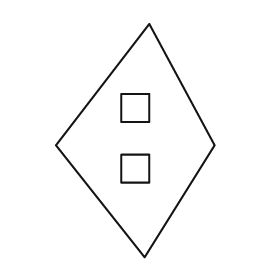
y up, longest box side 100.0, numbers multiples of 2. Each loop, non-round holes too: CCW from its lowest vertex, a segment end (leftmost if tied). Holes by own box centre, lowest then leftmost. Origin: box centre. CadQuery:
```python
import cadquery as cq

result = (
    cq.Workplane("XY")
    .moveTo(4.0, -50.0)
    .lineTo(34.0, -2.0)
    .lineTo(6.0, 50.0)
    .lineTo(-34.0, -2.0)
    .close()
    .moveTo(-6.0, -18.0)
    .lineTo(6.0, -18.0)
    .lineTo(6.0, -6.0)
    .lineTo(-6.0, -6.0)
    .close()
    .moveTo(-6.0, 8.0)
    .lineTo(6.0, 8.0)
    .lineTo(6.0, 20.0)
    .lineTo(-6.0, 20.0)
    .close()
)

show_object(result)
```